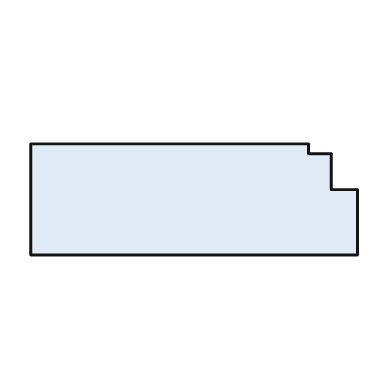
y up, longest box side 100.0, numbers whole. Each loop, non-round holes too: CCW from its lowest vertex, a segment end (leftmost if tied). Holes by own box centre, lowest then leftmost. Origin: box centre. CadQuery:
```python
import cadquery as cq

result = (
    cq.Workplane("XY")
    .moveTo(-50.0, -17.0)
    .lineTo(50.0, -17.0)
    .lineTo(50.0, 3.0)
    .lineTo(42.0, 3.0)
    .lineTo(42.0, 14.0)
    .lineTo(35.0, 14.0)
    .lineTo(35.0, 17.0)
    .lineTo(-50.0, 17.0)
    .close()
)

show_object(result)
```